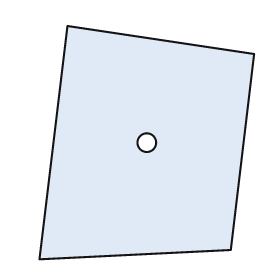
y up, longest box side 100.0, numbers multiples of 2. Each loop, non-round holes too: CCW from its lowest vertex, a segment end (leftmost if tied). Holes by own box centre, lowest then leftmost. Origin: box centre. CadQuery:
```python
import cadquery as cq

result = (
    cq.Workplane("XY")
    .moveTo(-46.0, -50.0)
    .lineTo(36.0, -46.0)
    .lineTo(46.0, 38.0)
    .lineTo(-34.0, 50.0)
    .close()
    .moveTo(0.0, 0.0)
    .circle(4.0)
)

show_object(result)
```